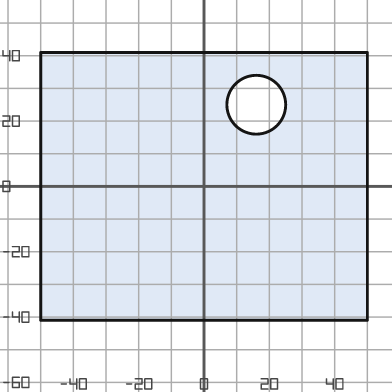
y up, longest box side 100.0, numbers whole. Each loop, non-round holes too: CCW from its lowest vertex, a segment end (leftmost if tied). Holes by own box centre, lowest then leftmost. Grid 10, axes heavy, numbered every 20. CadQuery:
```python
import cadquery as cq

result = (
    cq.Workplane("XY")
    .moveTo(-50.0, -41.0)
    .lineTo(50.0, -41.0)
    .lineTo(50.0, 41.0)
    .lineTo(-50.0, 41.0)
    .close()
    .moveTo(16.0, 25.0)
    .circle(9.0)
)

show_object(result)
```